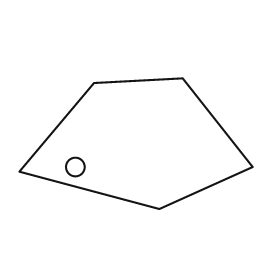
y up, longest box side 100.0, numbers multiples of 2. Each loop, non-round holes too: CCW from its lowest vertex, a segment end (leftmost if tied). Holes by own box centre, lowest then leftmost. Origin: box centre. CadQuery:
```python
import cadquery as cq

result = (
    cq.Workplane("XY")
    .moveTo(10.0, -28.0)
    .lineTo(50.0, -10.0)
    .lineTo(20.0, 28.0)
    .lineTo(-18.0, 26.0)
    .lineTo(-50.0, -12.0)
    .close()
    .moveTo(-26.0, -10.0)
    .circle(4.0)
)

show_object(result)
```